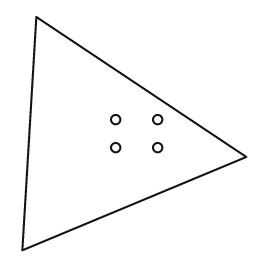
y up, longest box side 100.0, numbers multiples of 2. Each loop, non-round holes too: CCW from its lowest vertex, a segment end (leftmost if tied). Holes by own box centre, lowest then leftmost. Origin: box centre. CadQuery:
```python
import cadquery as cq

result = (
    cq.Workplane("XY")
    .moveTo(-48.0, -50.0)
    .lineTo(48.0, -10.0)
    .lineTo(-42.0, 50.0)
    .close()
    .moveTo(-8.0, -6.0)
    .circle(2.0)
    .moveTo(10.0, -6.0)
    .circle(2.0)
    .moveTo(-8.0, 6.0)
    .circle(2.0)
    .moveTo(10.0, 6.0)
    .circle(2.0)
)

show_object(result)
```